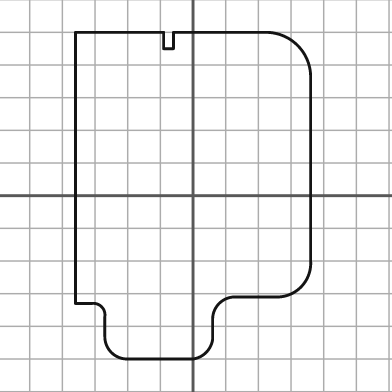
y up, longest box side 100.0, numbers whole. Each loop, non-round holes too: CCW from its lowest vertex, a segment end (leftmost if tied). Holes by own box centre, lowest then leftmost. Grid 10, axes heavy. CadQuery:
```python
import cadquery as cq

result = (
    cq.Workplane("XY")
    .moveTo(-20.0, -50.0)
    .lineTo(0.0, -50.0)
    .threePointArc((4.0, -48.0), (6.0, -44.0))
    .lineTo(6.0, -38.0)
    .threePointArc((8.0, -33.0), (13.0, -31.0))
    .lineTo(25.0, -31.0)
    .threePointArc((33.0, -28.0), (36.0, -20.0))
    .lineTo(36.0, 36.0)
    .threePointArc((32.0, 46.0), (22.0, 50.0))
    .lineTo(-6.0, 50.0)
    .lineTo(-6.0, 45.0)
    .lineTo(-9.0, 45.0)
    .lineTo(-9.0, 50.0)
    .lineTo(-36.0, 50.0)
    .lineTo(-36.0, -33.0)
    .lineTo(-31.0, -33.0)
    .threePointArc((-28.0, -34.0), (-27.0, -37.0))
    .lineTo(-27.0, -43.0)
    .threePointArc((-25.0, -48.0), (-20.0, -50.0))
    .close()
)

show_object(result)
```